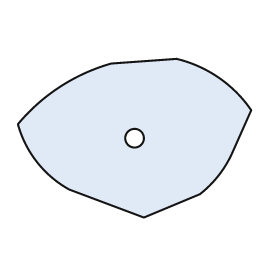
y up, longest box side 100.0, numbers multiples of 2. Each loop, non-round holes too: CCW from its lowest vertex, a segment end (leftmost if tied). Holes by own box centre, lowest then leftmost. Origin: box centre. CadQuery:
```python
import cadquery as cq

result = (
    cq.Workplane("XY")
    .moveTo(4.0, -34.0)
    .lineTo(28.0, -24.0)
    .threePointArc((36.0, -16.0), (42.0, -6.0))
    .lineTo(50.0, 12.0)
    .threePointArc((36.0, 26.0), (18.0, 34.0))
    .lineTo(-10.0, 32.0)
    .threePointArc((-32.0, 22.0), (-50.0, 6.0))
    .threePointArc((-42.0, -10.0), (-28.0, -22.0))
    .close()
    .moveTo(0.0, 0.0)
    .circle(4.0)
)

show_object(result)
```